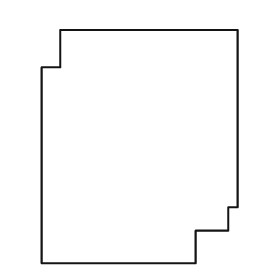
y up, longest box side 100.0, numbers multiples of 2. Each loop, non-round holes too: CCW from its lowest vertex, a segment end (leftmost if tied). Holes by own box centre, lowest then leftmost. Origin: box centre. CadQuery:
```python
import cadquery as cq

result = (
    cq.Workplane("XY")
    .moveTo(-42.0, -50.0)
    .lineTo(24.0, -50.0)
    .lineTo(24.0, -36.0)
    .lineTo(38.0, -36.0)
    .lineTo(38.0, -26.0)
    .lineTo(42.0, -26.0)
    .lineTo(42.0, 50.0)
    .lineTo(-34.0, 50.0)
    .lineTo(-34.0, 34.0)
    .lineTo(-42.0, 34.0)
    .close()
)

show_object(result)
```